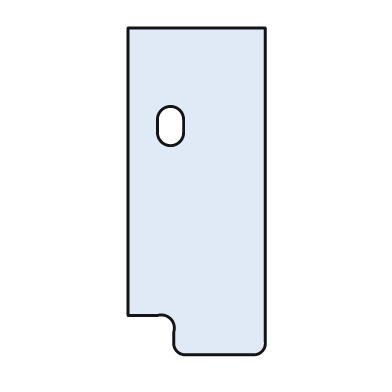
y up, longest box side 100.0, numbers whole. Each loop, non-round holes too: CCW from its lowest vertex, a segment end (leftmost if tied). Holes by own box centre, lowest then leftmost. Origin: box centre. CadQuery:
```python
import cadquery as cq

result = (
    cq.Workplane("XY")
    .moveTo(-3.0, -50.0)
    .lineTo(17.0, -50.0)
    .threePointArc((20.0, -49.0), (21.0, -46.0))
    .lineTo(21.0, 50.0)
    .lineTo(-21.0, 50.0)
    .lineTo(-21.0, -38.0)
    .lineTo(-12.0, -38.0)
    .threePointArc((-8.0, -39.0), (-7.0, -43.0))
    .lineTo(-7.0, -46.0)
    .threePointArc((-6.0, -49.0), (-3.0, -50.0))
    .close()
    .moveTo(-12.0, 18.0)
    .threePointArc((-8.0, 14.0), (-4.0, 18.0))
    .lineTo(-4.0, 22.0)
    .threePointArc((-8.0, 26.0), (-12.0, 22.0))
    .close()
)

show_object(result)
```